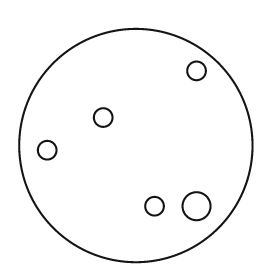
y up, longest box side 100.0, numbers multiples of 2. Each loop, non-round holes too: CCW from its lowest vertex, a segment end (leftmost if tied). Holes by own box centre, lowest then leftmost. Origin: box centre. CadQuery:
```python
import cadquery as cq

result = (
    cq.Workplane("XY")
    .moveTo(0.0, 0.0)
    .circle(50.0)
    .moveTo(8.0, -26.0)
    .circle(4.0)
    .moveTo(26.0, -26.0)
    .circle(6.0)
    .moveTo(-38.0, -2.0)
    .circle(4.0)
    .moveTo(-14.0, 12.0)
    .circle(4.0)
    .moveTo(26.0, 32.0)
    .circle(4.0)
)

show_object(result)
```